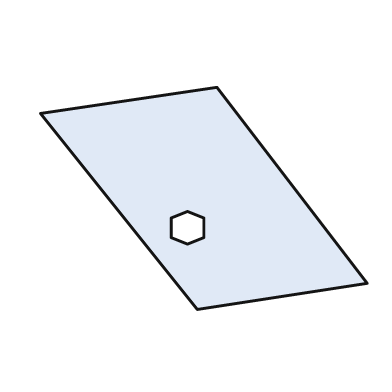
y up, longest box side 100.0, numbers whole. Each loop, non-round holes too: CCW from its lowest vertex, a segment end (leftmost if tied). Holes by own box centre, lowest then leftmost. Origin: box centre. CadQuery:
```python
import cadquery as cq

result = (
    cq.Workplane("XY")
    .moveTo(-2.0, -34.0)
    .lineTo(50.0, -26.0)
    .lineTo(4.0, 34.0)
    .lineTo(-50.0, 26.0)
    .close()
    .moveTo(-5.0, -14.0)
    .lineTo(0.0, -12.0)
    .lineTo(0.0, -6.0)
    .lineTo(-5.0, -4.0)
    .lineTo(-10.0, -6.0)
    .lineTo(-10.0, -12.0)
    .close()
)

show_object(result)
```